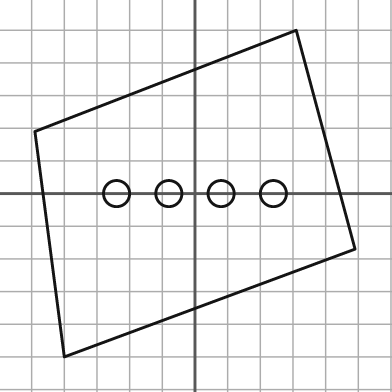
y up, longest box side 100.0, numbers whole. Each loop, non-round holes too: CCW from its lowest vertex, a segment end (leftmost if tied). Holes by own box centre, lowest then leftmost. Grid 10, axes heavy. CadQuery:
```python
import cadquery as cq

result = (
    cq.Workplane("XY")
    .moveTo(-40.0, -50.0)
    .lineTo(49.0, -17.0)
    .lineTo(31.0, 50.0)
    .lineTo(-49.0, 19.0)
    .close()
    .moveTo(-24.0, 0.0)
    .circle(4.0)
    .moveTo(-8.0, 0.0)
    .circle(4.0)
    .moveTo(8.0, 0.0)
    .circle(4.0)
    .moveTo(24.0, 0.0)
    .circle(4.0)
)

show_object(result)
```